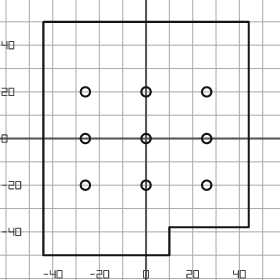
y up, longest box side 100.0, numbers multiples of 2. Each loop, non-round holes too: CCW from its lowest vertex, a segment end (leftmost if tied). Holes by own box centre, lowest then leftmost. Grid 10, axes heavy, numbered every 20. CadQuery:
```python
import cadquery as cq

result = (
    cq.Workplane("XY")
    .moveTo(-44.0, -50.0)
    .lineTo(10.0, -50.0)
    .lineTo(10.0, -38.0)
    .lineTo(44.0, -38.0)
    .lineTo(44.0, 50.0)
    .lineTo(-44.0, 50.0)
    .close()
    .moveTo(-26.0, -20.0)
    .circle(2.0)
    .moveTo(0.0, -20.0)
    .circle(2.0)
    .moveTo(26.0, -20.0)
    .circle(2.0)
    .moveTo(-26.0, 0.0)
    .circle(2.0)
    .moveTo(0.0, 0.0)
    .circle(2.0)
    .moveTo(26.0, 0.0)
    .circle(2.0)
    .moveTo(-26.0, 20.0)
    .circle(2.0)
    .moveTo(0.0, 20.0)
    .circle(2.0)
    .moveTo(26.0, 20.0)
    .circle(2.0)
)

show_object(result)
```